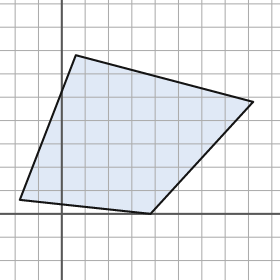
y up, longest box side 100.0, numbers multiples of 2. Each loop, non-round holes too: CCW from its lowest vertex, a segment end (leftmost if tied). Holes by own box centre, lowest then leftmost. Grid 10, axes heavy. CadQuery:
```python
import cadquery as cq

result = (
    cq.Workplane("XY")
    .moveTo(38.0, 0.0)
    .lineTo(82.0, 48.0)
    .lineTo(6.0, 68.0)
    .lineTo(-18.0, 6.0)
    .close()
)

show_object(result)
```